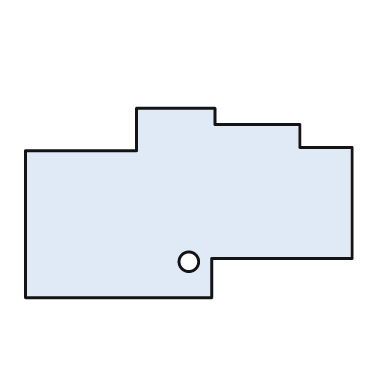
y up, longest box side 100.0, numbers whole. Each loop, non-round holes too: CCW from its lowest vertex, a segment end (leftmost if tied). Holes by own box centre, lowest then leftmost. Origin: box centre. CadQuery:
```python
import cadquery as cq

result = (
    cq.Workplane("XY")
    .moveTo(-50.0, -29.0)
    .lineTo(7.0, -29.0)
    .lineTo(7.0, -17.0)
    .lineTo(50.0, -17.0)
    .lineTo(50.0, 17.0)
    .lineTo(34.0, 17.0)
    .lineTo(34.0, 24.0)
    .lineTo(8.0, 24.0)
    .lineTo(8.0, 29.0)
    .lineTo(-16.0, 29.0)
    .lineTo(-16.0, 16.0)
    .lineTo(-50.0, 16.0)
    .close()
    .moveTo(0.0, -18.0)
    .circle(3.0)
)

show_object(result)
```